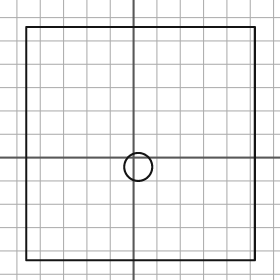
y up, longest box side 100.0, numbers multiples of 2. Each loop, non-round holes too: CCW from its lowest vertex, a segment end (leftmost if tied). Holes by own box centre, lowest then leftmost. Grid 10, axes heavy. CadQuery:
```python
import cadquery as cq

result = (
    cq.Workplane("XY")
    .moveTo(-46.0, -44.0)
    .lineTo(52.0, -44.0)
    .lineTo(52.0, 56.0)
    .lineTo(-46.0, 56.0)
    .close()
    .moveTo(2.0, -4.0)
    .circle(6.0)
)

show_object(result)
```